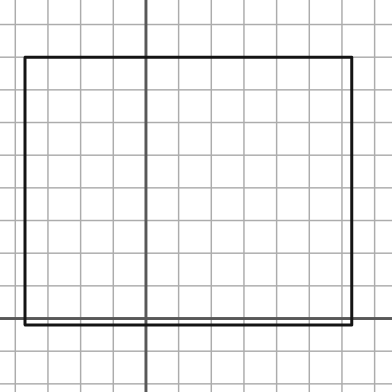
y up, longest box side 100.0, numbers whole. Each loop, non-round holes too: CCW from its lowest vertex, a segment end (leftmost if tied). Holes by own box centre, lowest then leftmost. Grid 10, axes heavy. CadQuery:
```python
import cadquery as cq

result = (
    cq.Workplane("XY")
    .moveTo(-37.0, -2.0)
    .lineTo(63.0, -2.0)
    .lineTo(63.0, 80.0)
    .lineTo(-37.0, 80.0)
    .close()
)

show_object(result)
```